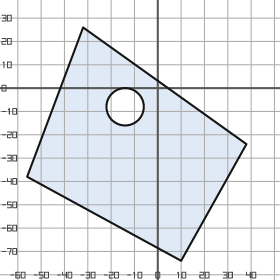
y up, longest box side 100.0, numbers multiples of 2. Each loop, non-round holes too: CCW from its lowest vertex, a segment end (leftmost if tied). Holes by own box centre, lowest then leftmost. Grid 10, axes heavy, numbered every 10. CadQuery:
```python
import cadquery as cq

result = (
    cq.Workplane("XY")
    .moveTo(10.0, -74.0)
    .lineTo(38.0, -24.0)
    .lineTo(-32.0, 26.0)
    .lineTo(-56.0, -38.0)
    .close()
    .moveTo(-14.0, -8.0)
    .circle(8.0)
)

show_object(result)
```